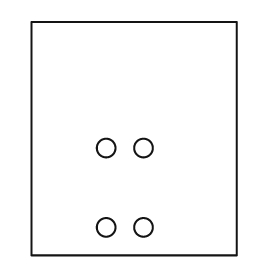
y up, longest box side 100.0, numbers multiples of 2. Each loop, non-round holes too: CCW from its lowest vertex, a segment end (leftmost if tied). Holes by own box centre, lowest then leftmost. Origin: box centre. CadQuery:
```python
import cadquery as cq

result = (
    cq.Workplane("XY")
    .moveTo(-44.0, -50.0)
    .lineTo(44.0, -50.0)
    .lineTo(44.0, 50.0)
    .lineTo(-44.0, 50.0)
    .close()
    .moveTo(-12.0, -38.0)
    .circle(4.0)
    .moveTo(4.0, -38.0)
    .circle(4.0)
    .moveTo(-12.0, -4.0)
    .circle(4.0)
    .moveTo(4.0, -4.0)
    .circle(4.0)
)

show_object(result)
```